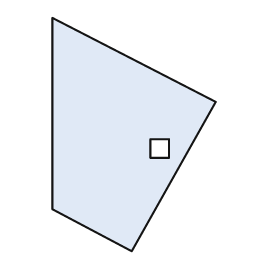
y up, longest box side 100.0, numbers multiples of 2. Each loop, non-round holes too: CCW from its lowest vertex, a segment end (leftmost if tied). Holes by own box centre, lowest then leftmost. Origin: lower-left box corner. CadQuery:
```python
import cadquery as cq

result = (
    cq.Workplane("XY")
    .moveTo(34.0, 0.0)
    .lineTo(70.0, 64.0)
    .lineTo(0.0, 100.0)
    .lineTo(0.0, 18.0)
    .close()
    .moveTo(42.0, 40.0)
    .lineTo(50.0, 40.0)
    .lineTo(50.0, 48.0)
    .lineTo(42.0, 48.0)
    .close()
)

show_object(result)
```